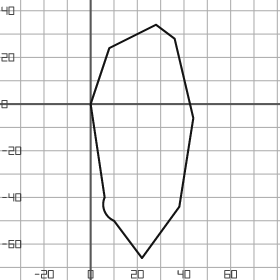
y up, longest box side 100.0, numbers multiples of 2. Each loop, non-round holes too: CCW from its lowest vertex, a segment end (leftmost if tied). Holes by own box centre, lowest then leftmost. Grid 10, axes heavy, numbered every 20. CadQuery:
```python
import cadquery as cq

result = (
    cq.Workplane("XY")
    .moveTo(22.0, -66.0)
    .lineTo(38.0, -44.0)
    .lineTo(44.0, -6.0)
    .lineTo(36.0, 28.0)
    .lineTo(28.0, 34.0)
    .lineTo(8.0, 24.0)
    .lineTo(0.0, 0.0)
    .lineTo(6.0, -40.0)
    .threePointArc((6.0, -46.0), (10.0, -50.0))
    .close()
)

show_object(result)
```